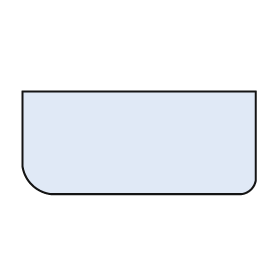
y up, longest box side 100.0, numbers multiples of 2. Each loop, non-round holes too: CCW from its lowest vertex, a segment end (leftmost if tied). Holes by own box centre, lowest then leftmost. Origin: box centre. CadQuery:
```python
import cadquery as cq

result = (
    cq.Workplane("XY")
    .moveTo(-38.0, -22.0)
    .lineTo(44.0, -22.0)
    .threePointArc((48.0, -20.0), (50.0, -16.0))
    .lineTo(50.0, 22.0)
    .lineTo(-50.0, 22.0)
    .lineTo(-50.0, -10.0)
    .threePointArc((-46.0, -18.0), (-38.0, -22.0))
    .close()
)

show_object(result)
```